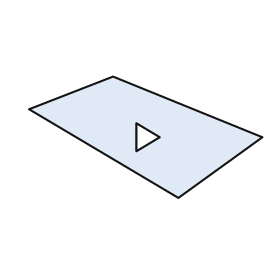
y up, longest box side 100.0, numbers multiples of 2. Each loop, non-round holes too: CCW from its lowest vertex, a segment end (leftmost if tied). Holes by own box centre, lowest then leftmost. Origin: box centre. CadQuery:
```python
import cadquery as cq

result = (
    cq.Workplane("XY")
    .moveTo(14.0, -26.0)
    .lineTo(50.0, 0.0)
    .lineTo(-14.0, 26.0)
    .lineTo(-50.0, 12.0)
    .close()
    .moveTo(-4.0, -6.0)
    .lineTo(6.0, 0.0)
    .lineTo(-4.0, 6.0)
    .close()
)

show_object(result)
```